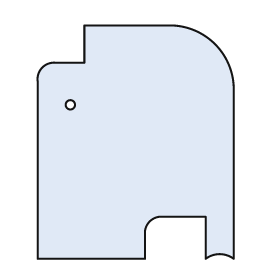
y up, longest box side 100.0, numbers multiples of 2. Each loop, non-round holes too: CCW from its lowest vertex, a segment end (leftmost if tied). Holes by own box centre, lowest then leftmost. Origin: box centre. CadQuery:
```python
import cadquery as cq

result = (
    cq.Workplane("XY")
    .moveTo(-42.0, -50.0)
    .lineTo(4.0, -50.0)
    .lineTo(4.0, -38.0)
    .threePointArc((6.0, -34.0), (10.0, -32.0))
    .lineTo(30.0, -32.0)
    .lineTo(30.0, -50.0)
    .threePointArc((36.0, -48.0), (42.0, -50.0))
    .lineTo(42.0, 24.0)
    .threePointArc((34.0, 42.0), (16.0, 50.0))
    .lineTo(-22.0, 50.0)
    .lineTo(-22.0, 34.0)
    .lineTo(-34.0, 34.0)
    .threePointArc((-40.0, 32.0), (-42.0, 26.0))
    .close()
    .moveTo(-28.0, 16.0)
    .circle(2.0)
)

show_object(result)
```